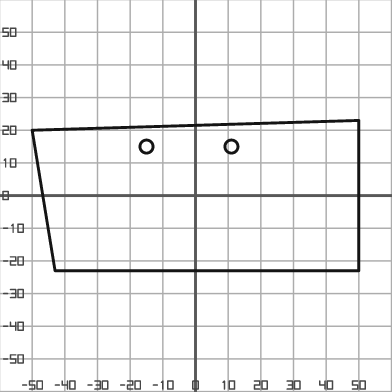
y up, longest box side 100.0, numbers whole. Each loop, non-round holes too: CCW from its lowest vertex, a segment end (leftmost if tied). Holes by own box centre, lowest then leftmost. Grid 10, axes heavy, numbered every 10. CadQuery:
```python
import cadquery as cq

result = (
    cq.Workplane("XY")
    .moveTo(-43.0, -23.0)
    .lineTo(50.0, -23.0)
    .lineTo(50.0, 23.0)
    .lineTo(-50.0, 20.0)
    .close()
    .moveTo(-15.0, 15.0)
    .circle(2.0)
    .moveTo(11.0, 15.0)
    .circle(2.0)
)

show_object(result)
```